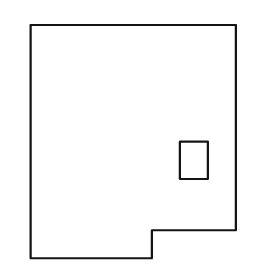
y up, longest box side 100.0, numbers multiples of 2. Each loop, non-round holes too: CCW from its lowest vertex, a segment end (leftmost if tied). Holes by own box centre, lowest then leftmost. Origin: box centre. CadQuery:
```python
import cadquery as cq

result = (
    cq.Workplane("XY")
    .moveTo(-44.0, -50.0)
    .lineTo(8.0, -50.0)
    .lineTo(8.0, -38.0)
    .lineTo(44.0, -38.0)
    .lineTo(44.0, 50.0)
    .lineTo(-44.0, 50.0)
    .close()
    .moveTo(20.0, -16.0)
    .lineTo(32.0, -16.0)
    .lineTo(32.0, 0.0)
    .lineTo(20.0, 0.0)
    .close()
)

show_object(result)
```